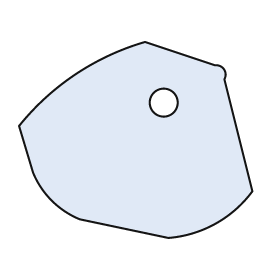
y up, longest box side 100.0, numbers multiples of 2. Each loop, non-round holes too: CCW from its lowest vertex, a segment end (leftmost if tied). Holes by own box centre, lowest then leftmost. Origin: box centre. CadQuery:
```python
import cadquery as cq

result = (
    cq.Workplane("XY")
    .moveTo(14.0, -42.0)
    .threePointArc((34.0, -36.0), (50.0, -22.0))
    .lineTo(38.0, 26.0)
    .threePointArc((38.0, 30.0), (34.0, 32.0))
    .lineTo(4.0, 42.0)
    .threePointArc((-26.0, 28.0), (-50.0, 6.0))
    .lineTo(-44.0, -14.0)
    .threePointArc((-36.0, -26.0), (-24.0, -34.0))
    .close()
    .moveTo(12.0, 16.0)
    .circle(6.0)
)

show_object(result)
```